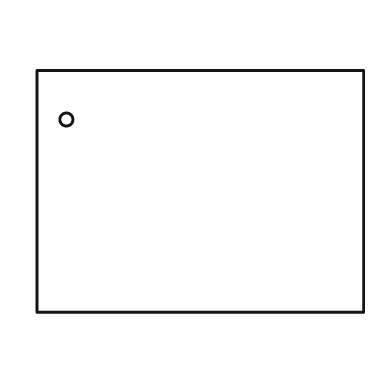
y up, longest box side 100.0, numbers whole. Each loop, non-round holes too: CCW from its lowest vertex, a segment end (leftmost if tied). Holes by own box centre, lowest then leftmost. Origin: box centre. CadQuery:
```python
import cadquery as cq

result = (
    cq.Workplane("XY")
    .moveTo(-50.0, -37.0)
    .lineTo(50.0, -37.0)
    .lineTo(50.0, 37.0)
    .lineTo(-50.0, 37.0)
    .close()
    .moveTo(-41.0, 22.0)
    .circle(2.0)
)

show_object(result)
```